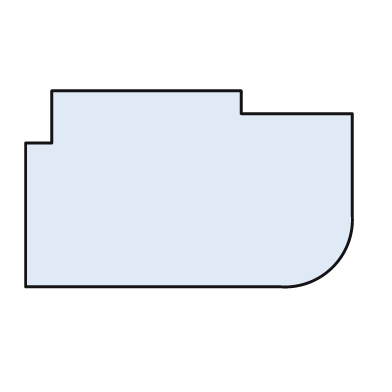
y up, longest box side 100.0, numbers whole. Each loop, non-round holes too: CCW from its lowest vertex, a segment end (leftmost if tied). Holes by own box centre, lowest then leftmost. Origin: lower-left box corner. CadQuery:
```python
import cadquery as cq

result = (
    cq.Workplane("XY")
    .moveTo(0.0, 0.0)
    .lineTo(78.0, 0.0)
    .threePointArc((94.0, 6.0), (100.0, 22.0))
    .lineTo(100.0, 53.0)
    .lineTo(66.0, 53.0)
    .lineTo(66.0, 60.0)
    .lineTo(8.0, 60.0)
    .lineTo(8.0, 44.0)
    .lineTo(0.0, 44.0)
    .close()
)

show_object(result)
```